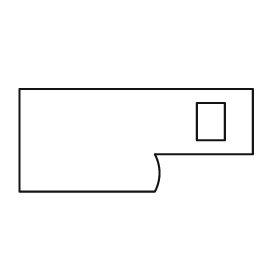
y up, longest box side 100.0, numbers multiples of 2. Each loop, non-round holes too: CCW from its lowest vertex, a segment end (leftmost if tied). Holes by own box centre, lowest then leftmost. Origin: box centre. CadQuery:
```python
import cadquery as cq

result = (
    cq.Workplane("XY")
    .moveTo(-50.0, -22.0)
    .lineTo(8.0, -22.0)
    .threePointArc((10.0, -14.0), (8.0, -6.0))
    .lineTo(50.0, -6.0)
    .lineTo(50.0, 22.0)
    .lineTo(-50.0, 22.0)
    .close()
    .moveTo(26.0, 0.0)
    .lineTo(38.0, 0.0)
    .lineTo(38.0, 16.0)
    .lineTo(26.0, 16.0)
    .close()
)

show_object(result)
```